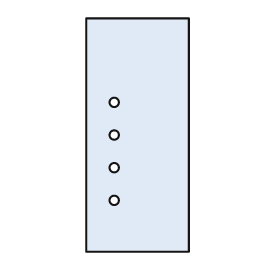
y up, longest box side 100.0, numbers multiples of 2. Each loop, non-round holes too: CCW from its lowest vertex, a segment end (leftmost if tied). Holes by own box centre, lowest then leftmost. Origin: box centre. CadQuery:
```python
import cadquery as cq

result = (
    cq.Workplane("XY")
    .moveTo(-22.0, -50.0)
    .lineTo(22.0, -50.0)
    .lineTo(22.0, 50.0)
    .lineTo(-22.0, 50.0)
    .close()
    .moveTo(-10.0, -28.0)
    .circle(2.0)
    .moveTo(-10.0, -14.0)
    .circle(2.0)
    .moveTo(-10.0, 0.0)
    .circle(2.0)
    .moveTo(-10.0, 14.0)
    .circle(2.0)
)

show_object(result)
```